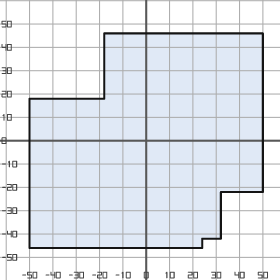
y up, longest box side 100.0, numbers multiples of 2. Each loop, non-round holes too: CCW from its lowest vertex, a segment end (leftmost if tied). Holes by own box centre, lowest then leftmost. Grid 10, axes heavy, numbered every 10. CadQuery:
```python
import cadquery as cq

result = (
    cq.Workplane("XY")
    .moveTo(-50.0, -46.0)
    .lineTo(24.0, -46.0)
    .lineTo(24.0, -42.0)
    .lineTo(32.0, -42.0)
    .lineTo(32.0, -22.0)
    .lineTo(50.0, -22.0)
    .lineTo(50.0, 46.0)
    .lineTo(-18.0, 46.0)
    .lineTo(-18.0, 18.0)
    .lineTo(-50.0, 18.0)
    .close()
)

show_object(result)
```